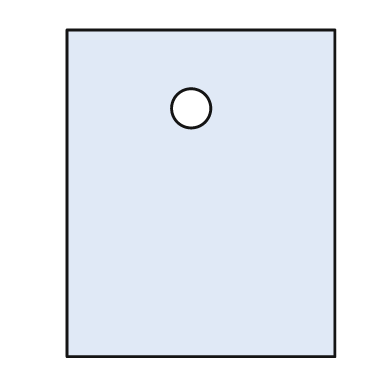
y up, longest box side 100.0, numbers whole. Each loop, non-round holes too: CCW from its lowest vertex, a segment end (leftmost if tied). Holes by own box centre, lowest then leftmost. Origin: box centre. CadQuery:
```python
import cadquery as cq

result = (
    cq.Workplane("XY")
    .moveTo(-41.0, -50.0)
    .lineTo(41.0, -50.0)
    .lineTo(41.0, 50.0)
    .lineTo(-41.0, 50.0)
    .close()
    .moveTo(-3.0, 26.0)
    .circle(6.0)
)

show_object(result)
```